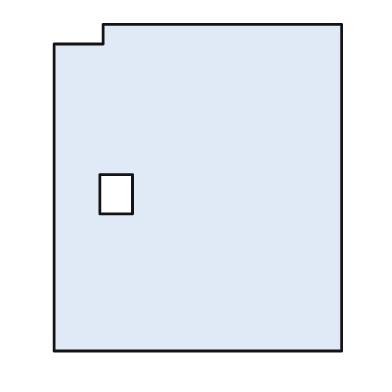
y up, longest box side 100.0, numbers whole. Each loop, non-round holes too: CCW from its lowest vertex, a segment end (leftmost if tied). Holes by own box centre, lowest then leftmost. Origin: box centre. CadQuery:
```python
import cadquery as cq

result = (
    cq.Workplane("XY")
    .moveTo(-44.0, -50.0)
    .lineTo(44.0, -50.0)
    .lineTo(44.0, 50.0)
    .lineTo(-29.0, 50.0)
    .lineTo(-29.0, 44.0)
    .lineTo(-44.0, 44.0)
    .close()
    .moveTo(-30.0, -8.0)
    .lineTo(-20.0, -8.0)
    .lineTo(-20.0, 4.0)
    .lineTo(-30.0, 4.0)
    .close()
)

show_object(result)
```